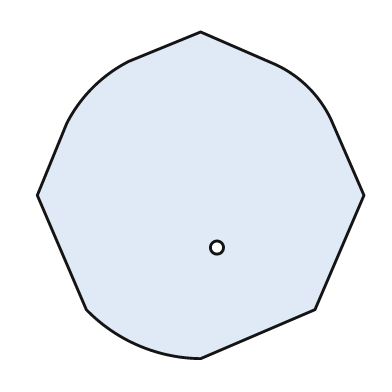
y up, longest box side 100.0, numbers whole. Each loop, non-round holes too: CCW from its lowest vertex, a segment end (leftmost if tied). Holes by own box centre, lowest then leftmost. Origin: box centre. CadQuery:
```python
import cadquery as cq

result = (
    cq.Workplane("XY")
    .moveTo(0.0, -50.0)
    .lineTo(35.0, -35.0)
    .lineTo(50.0, 0.0)
    .lineTo(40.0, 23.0)
    .threePointArc((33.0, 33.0), (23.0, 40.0))
    .lineTo(0.0, 50.0)
    .lineTo(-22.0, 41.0)
    .threePointArc((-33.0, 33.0), (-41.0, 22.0))
    .lineTo(-50.0, 0.0)
    .lineTo(-35.0, -35.0)
    .threePointArc((-19.0, -46.0), (0.0, -50.0))
    .close()
    .moveTo(5.0, -16.0)
    .circle(2.0)
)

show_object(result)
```